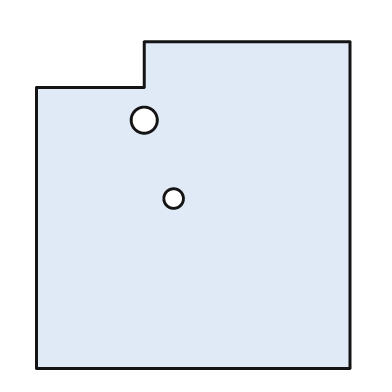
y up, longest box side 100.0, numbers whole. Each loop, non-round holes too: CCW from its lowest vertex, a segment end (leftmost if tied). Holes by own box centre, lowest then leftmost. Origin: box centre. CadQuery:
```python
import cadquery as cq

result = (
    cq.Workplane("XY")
    .moveTo(-48.0, -50.0)
    .lineTo(48.0, -50.0)
    .lineTo(48.0, 50.0)
    .lineTo(-15.0, 50.0)
    .lineTo(-15.0, 36.0)
    .lineTo(-48.0, 36.0)
    .close()
    .moveTo(-6.0, 2.0)
    .circle(3.0)
    .moveTo(-15.0, 26.0)
    .circle(4.0)
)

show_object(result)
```